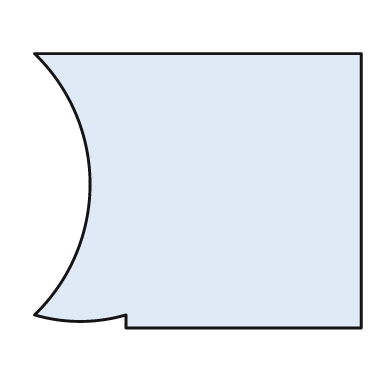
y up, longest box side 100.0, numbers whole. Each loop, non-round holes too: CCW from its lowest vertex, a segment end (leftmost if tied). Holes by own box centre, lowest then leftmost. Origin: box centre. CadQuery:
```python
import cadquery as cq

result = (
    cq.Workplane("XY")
    .moveTo(-22.0, -42.0)
    .lineTo(50.0, -42.0)
    .lineTo(50.0, 42.0)
    .lineTo(-50.0, 42.0)
    .threePointArc((-33.0, 2.0), (-50.0, -38.0))
    .threePointArc((-36.0, -40.0), (-22.0, -38.0))
    .close()
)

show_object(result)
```